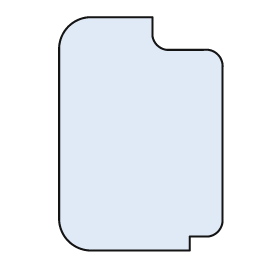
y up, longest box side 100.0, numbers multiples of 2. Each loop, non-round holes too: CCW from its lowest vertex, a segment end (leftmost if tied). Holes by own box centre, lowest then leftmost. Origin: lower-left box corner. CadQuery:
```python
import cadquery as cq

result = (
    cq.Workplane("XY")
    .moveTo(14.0, 0.0)
    .lineTo(56.0, 0.0)
    .lineTo(56.0, 6.0)
    .lineTo(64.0, 6.0)
    .threePointArc((68.0, 8.0), (70.0, 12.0))
    .lineTo(70.0, 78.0)
    .threePointArc((68.0, 84.0), (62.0, 86.0))
    .lineTo(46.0, 86.0)
    .threePointArc((42.0, 88.0), (40.0, 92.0))
    .lineTo(40.0, 100.0)
    .lineTo(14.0, 100.0)
    .threePointArc((4.0, 96.0), (0.0, 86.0))
    .lineTo(0.0, 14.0)
    .threePointArc((4.0, 4.0), (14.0, 0.0))
    .close()
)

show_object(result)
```